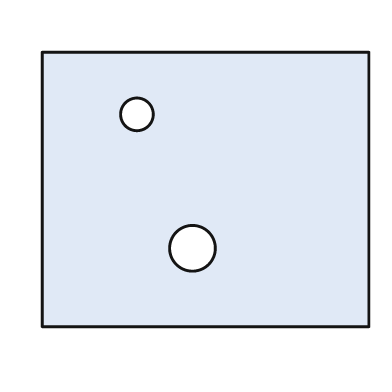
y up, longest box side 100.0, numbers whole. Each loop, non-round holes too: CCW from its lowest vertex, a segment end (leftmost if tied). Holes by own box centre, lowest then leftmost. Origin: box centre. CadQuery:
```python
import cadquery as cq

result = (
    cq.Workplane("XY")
    .moveTo(-50.0, -42.0)
    .lineTo(50.0, -42.0)
    .lineTo(50.0, 42.0)
    .lineTo(-50.0, 42.0)
    .close()
    .moveTo(-4.0, -18.0)
    .circle(7.0)
    .moveTo(-21.0, 23.0)
    .circle(5.0)
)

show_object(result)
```